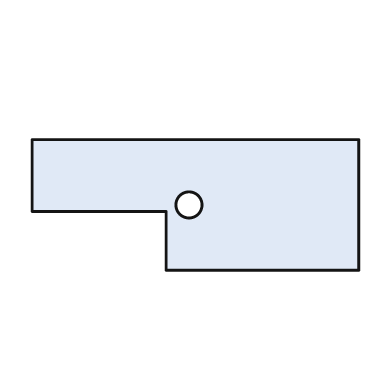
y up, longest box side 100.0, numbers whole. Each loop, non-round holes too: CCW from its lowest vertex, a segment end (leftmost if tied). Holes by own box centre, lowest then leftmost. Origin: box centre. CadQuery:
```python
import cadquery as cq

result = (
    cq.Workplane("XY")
    .moveTo(-9.0, -20.0)
    .lineTo(50.0, -20.0)
    .lineTo(50.0, 20.0)
    .lineTo(-50.0, 20.0)
    .lineTo(-50.0, -2.0)
    .lineTo(-9.0, -2.0)
    .close()
    .moveTo(-2.0, 0.0)
    .circle(4.0)
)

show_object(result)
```